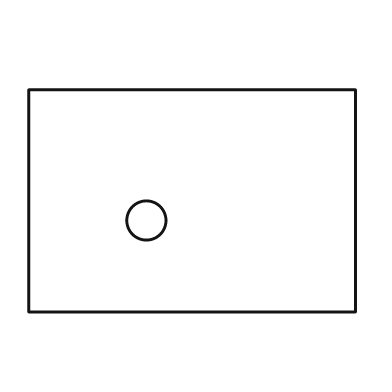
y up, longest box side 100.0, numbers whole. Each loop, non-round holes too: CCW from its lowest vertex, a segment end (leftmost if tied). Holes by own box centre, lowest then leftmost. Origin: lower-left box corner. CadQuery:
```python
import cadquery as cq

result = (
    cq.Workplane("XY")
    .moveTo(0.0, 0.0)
    .lineTo(100.0, 0.0)
    .lineTo(100.0, 68.0)
    .lineTo(0.0, 68.0)
    .close()
    .moveTo(36.0, 28.0)
    .circle(6.0)
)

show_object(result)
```